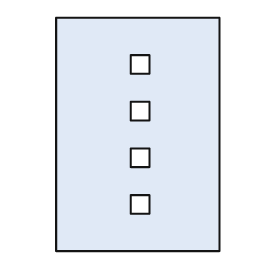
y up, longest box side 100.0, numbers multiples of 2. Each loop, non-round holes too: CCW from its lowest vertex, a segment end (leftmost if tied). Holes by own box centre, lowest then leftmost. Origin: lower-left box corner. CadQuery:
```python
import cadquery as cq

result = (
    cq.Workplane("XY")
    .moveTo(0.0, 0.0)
    .lineTo(70.0, 0.0)
    .lineTo(70.0, 100.0)
    .lineTo(0.0, 100.0)
    .close()
    .moveTo(32.0, 16.0)
    .lineTo(40.0, 16.0)
    .lineTo(40.0, 24.0)
    .lineTo(32.0, 24.0)
    .close()
    .moveTo(32.0, 36.0)
    .lineTo(40.0, 36.0)
    .lineTo(40.0, 44.0)
    .lineTo(32.0, 44.0)
    .close()
    .moveTo(32.0, 56.0)
    .lineTo(40.0, 56.0)
    .lineTo(40.0, 64.0)
    .lineTo(32.0, 64.0)
    .close()
    .moveTo(32.0, 76.0)
    .lineTo(40.0, 76.0)
    .lineTo(40.0, 84.0)
    .lineTo(32.0, 84.0)
    .close()
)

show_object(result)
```